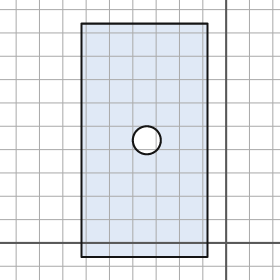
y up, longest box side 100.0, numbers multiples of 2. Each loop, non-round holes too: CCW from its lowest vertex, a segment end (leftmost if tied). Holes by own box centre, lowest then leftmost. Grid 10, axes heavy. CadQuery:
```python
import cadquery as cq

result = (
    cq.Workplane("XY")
    .moveTo(-62.0, -6.0)
    .lineTo(-8.0, -6.0)
    .lineTo(-8.0, 94.0)
    .lineTo(-62.0, 94.0)
    .close()
    .moveTo(-34.0, 44.0)
    .circle(6.0)
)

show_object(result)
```